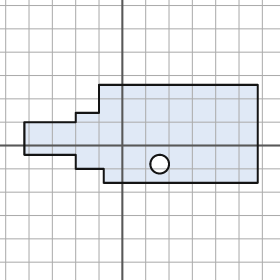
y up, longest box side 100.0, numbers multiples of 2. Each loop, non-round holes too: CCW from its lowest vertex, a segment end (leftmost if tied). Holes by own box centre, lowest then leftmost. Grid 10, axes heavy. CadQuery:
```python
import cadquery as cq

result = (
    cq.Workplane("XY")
    .moveTo(-8.0, -16.0)
    .lineTo(58.0, -16.0)
    .lineTo(58.0, 26.0)
    .lineTo(-10.0, 26.0)
    .lineTo(-10.0, 14.0)
    .lineTo(-20.0, 14.0)
    .lineTo(-20.0, 10.0)
    .lineTo(-42.0, 10.0)
    .lineTo(-42.0, -4.0)
    .lineTo(-20.0, -4.0)
    .lineTo(-20.0, -10.0)
    .lineTo(-8.0, -10.0)
    .close()
    .moveTo(16.0, -8.0)
    .circle(4.0)
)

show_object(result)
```